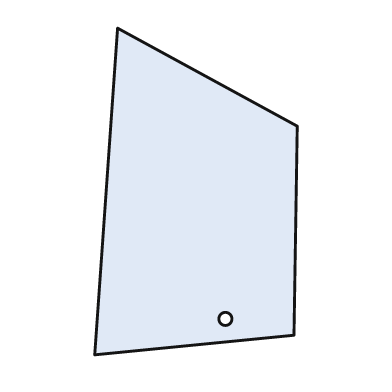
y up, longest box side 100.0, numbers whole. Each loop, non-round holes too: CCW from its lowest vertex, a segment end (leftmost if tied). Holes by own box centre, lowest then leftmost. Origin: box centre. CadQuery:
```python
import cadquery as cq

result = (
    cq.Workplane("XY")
    .moveTo(-31.0, -50.0)
    .lineTo(30.0, -44.0)
    .lineTo(31.0, 20.0)
    .lineTo(-24.0, 50.0)
    .close()
    .moveTo(9.0, -39.0)
    .circle(2.0)
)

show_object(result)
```